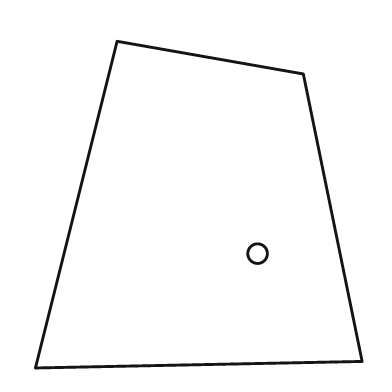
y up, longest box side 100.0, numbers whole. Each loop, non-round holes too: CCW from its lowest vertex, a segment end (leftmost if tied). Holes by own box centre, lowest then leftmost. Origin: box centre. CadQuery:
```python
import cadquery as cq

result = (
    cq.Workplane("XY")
    .moveTo(-50.0, -50.0)
    .lineTo(50.0, -48.0)
    .lineTo(32.0, 40.0)
    .lineTo(-25.0, 50.0)
    .close()
    .moveTo(18.0, -15.0)
    .circle(3.0)
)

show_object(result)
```